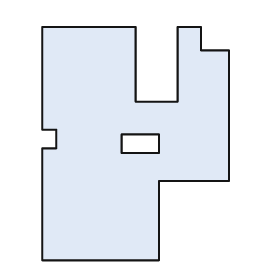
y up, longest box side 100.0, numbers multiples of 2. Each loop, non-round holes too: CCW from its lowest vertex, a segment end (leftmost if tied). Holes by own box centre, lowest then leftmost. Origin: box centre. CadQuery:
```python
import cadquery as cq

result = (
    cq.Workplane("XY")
    .moveTo(-40.0, -50.0)
    .lineTo(10.0, -50.0)
    .lineTo(10.0, -16.0)
    .lineTo(40.0, -16.0)
    .lineTo(40.0, 40.0)
    .lineTo(28.0, 40.0)
    .lineTo(28.0, 50.0)
    .lineTo(18.0, 50.0)
    .lineTo(18.0, 18.0)
    .lineTo(0.0, 18.0)
    .lineTo(0.0, 50.0)
    .lineTo(-40.0, 50.0)
    .lineTo(-40.0, 6.0)
    .lineTo(-34.0, 6.0)
    .lineTo(-34.0, -2.0)
    .lineTo(-40.0, -2.0)
    .close()
    .moveTo(-6.0, -4.0)
    .lineTo(10.0, -4.0)
    .lineTo(10.0, 4.0)
    .lineTo(-6.0, 4.0)
    .close()
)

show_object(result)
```